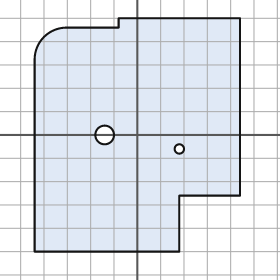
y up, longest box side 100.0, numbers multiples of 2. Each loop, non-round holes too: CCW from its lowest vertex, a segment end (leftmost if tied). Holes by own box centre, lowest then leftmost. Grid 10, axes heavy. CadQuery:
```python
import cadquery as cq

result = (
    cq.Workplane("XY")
    .moveTo(-44.0, -50.0)
    .lineTo(18.0, -50.0)
    .lineTo(18.0, -26.0)
    .lineTo(44.0, -26.0)
    .lineTo(44.0, 50.0)
    .lineTo(-8.0, 50.0)
    .lineTo(-8.0, 46.0)
    .lineTo(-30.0, 46.0)
    .threePointArc((-40.0, 42.0), (-44.0, 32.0))
    .close()
    .moveTo(18.0, -6.0)
    .circle(2.0)
    .moveTo(-14.0, 0.0)
    .circle(4.0)
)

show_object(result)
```